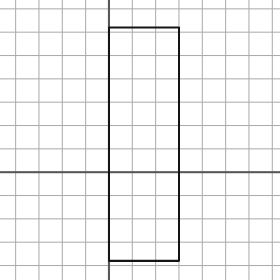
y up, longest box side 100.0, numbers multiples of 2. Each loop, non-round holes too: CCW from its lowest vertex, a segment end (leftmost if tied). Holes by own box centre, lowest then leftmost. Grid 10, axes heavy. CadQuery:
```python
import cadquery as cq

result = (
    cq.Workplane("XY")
    .moveTo(0.0, -38.0)
    .lineTo(30.0, -38.0)
    .lineTo(30.0, 62.0)
    .lineTo(0.0, 62.0)
    .close()
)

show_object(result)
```